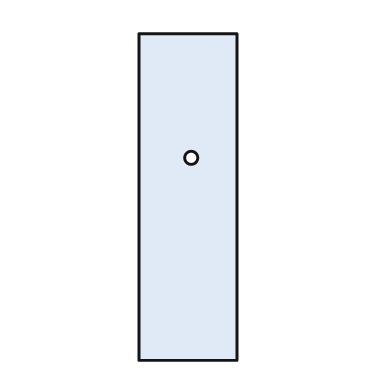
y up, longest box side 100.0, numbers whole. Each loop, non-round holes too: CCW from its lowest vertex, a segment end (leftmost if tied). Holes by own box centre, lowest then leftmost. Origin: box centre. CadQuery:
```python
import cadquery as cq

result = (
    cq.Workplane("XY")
    .moveTo(-15.0, -50.0)
    .lineTo(15.0, -50.0)
    .lineTo(15.0, 50.0)
    .lineTo(-15.0, 50.0)
    .close()
    .moveTo(1.0, 12.0)
    .circle(2.0)
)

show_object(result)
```